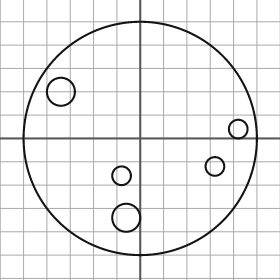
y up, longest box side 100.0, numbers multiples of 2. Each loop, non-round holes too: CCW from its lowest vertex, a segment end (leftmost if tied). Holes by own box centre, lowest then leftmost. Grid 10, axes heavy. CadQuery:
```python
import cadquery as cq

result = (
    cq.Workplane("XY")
    .moveTo(0.0, 0.0)
    .circle(50.0)
    .moveTo(-6.0, -34.0)
    .circle(6.0)
    .moveTo(-8.0, -16.0)
    .circle(4.0)
    .moveTo(32.0, -12.0)
    .circle(4.0)
    .moveTo(42.0, 4.0)
    .circle(4.0)
    .moveTo(-34.0, 20.0)
    .circle(6.0)
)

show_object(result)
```